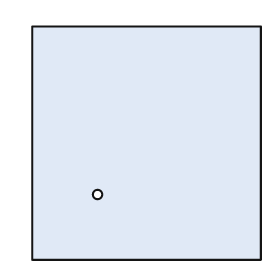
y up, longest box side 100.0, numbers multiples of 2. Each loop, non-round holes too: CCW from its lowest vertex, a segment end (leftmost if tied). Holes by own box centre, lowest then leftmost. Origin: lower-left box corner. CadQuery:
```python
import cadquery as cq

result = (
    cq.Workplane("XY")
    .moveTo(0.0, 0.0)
    .lineTo(98.0, 0.0)
    .lineTo(98.0, 100.0)
    .lineTo(0.0, 100.0)
    .close()
    .moveTo(28.0, 28.0)
    .circle(2.0)
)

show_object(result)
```